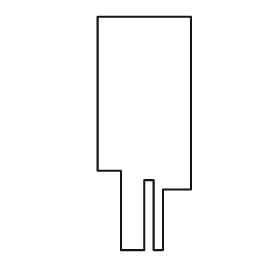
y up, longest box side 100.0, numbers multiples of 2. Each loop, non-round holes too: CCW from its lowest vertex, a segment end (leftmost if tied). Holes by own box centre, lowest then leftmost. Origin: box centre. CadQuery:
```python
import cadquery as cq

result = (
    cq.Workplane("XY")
    .moveTo(-10.0, -50.0)
    .lineTo(0.0, -50.0)
    .lineTo(0.0, -20.0)
    .lineTo(4.0, -20.0)
    .lineTo(4.0, -50.0)
    .lineTo(8.0, -50.0)
    .lineTo(8.0, -24.0)
    .lineTo(20.0, -24.0)
    .lineTo(20.0, 50.0)
    .lineTo(-20.0, 50.0)
    .lineTo(-20.0, -16.0)
    .lineTo(-10.0, -16.0)
    .close()
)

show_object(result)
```